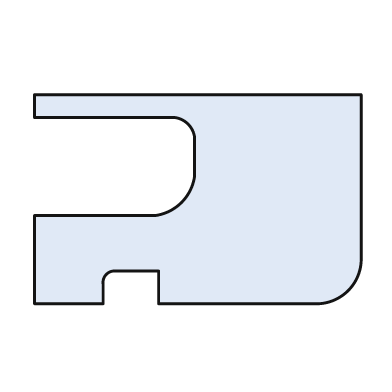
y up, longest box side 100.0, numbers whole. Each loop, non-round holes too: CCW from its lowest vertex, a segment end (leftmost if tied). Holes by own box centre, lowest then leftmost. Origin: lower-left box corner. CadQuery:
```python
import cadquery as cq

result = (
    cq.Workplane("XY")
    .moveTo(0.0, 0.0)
    .lineTo(21.0, 0.0)
    .lineTo(21.0, 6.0)
    .threePointArc((22.0, 9.0), (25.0, 10.0))
    .lineTo(38.0, 10.0)
    .lineTo(38.0, 0.0)
    .lineTo(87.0, 0.0)
    .threePointArc((96.0, 4.0), (100.0, 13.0))
    .lineTo(100.0, 64.0)
    .lineTo(0.0, 64.0)
    .lineTo(0.0, 57.0)
    .lineTo(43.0, 57.0)
    .threePointArc((47.0, 55.0), (49.0, 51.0))
    .lineTo(49.0, 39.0)
    .threePointArc((45.0, 31.0), (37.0, 27.0))
    .lineTo(0.0, 27.0)
    .close()
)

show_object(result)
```